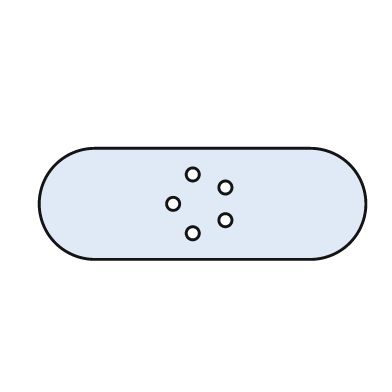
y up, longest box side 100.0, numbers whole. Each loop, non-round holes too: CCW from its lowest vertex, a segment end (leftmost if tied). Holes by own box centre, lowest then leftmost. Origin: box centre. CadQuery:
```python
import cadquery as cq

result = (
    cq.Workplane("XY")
    .moveTo(-33.0, -17.0)
    .lineTo(33.0, -17.0)
    .threePointArc((50.0, 0.0), (33.0, 17.0))
    .lineTo(-33.0, 17.0)
    .threePointArc((-50.0, 0.0), (-33.0, -17.0))
    .close()
    .moveTo(-3.0, -9.0)
    .circle(2.0)
    .moveTo(7.0, -5.0)
    .circle(2.0)
    .moveTo(-9.0, 0.0)
    .circle(2.0)
    .moveTo(7.0, 5.0)
    .circle(2.0)
    .moveTo(-3.0, 9.0)
    .circle(2.0)
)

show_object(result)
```